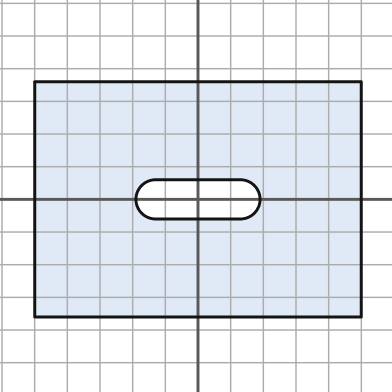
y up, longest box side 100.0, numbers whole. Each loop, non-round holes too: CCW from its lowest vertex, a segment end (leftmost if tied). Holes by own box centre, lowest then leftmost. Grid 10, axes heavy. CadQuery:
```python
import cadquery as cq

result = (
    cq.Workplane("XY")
    .moveTo(-50.0, -36.0)
    .lineTo(50.0, -36.0)
    .lineTo(50.0, 36.0)
    .lineTo(-50.0, 36.0)
    .close()
    .moveTo(-13.0, -6.0)
    .lineTo(13.0, -6.0)
    .threePointArc((19.0, 0.0), (13.0, 6.0))
    .lineTo(-13.0, 6.0)
    .threePointArc((-19.0, 0.0), (-13.0, -6.0))
    .close()
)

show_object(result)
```